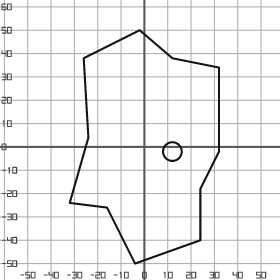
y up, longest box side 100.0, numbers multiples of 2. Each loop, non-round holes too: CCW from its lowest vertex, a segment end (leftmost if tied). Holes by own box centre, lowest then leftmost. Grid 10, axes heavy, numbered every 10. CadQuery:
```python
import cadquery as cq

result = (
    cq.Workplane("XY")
    .moveTo(-4.0, -50.0)
    .lineTo(24.0, -40.0)
    .lineTo(24.0, -18.0)
    .lineTo(32.0, -2.0)
    .lineTo(32.0, 34.0)
    .lineTo(12.0, 38.0)
    .lineTo(-2.0, 50.0)
    .lineTo(-26.0, 38.0)
    .lineTo(-24.0, 4.0)
    .lineTo(-32.0, -24.0)
    .lineTo(-16.0, -26.0)
    .close()
    .moveTo(12.0, -2.0)
    .circle(4.0)
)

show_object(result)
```